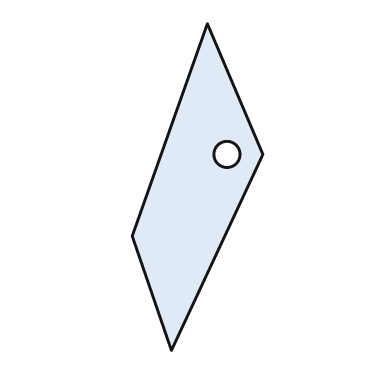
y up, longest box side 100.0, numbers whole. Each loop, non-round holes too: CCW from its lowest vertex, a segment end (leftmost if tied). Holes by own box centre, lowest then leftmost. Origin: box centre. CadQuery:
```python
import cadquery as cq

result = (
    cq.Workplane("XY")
    .moveTo(-8.0, -50.0)
    .lineTo(20.0, 10.0)
    .lineTo(3.0, 50.0)
    .lineTo(-20.0, -15.0)
    .close()
    .moveTo(9.0, 10.0)
    .circle(4.0)
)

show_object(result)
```